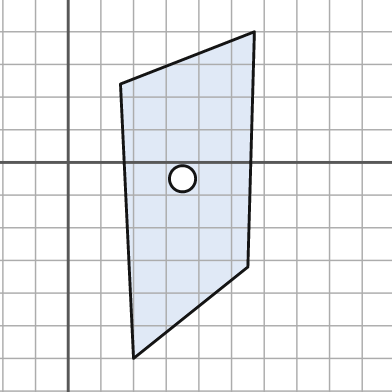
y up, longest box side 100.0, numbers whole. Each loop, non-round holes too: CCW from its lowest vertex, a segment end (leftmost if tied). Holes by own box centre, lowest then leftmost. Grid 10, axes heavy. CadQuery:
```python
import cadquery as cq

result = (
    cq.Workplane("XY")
    .moveTo(20.0, -60.0)
    .lineTo(55.0, -32.0)
    .lineTo(57.0, 40.0)
    .lineTo(16.0, 24.0)
    .close()
    .moveTo(35.0, -5.0)
    .circle(4.0)
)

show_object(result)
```